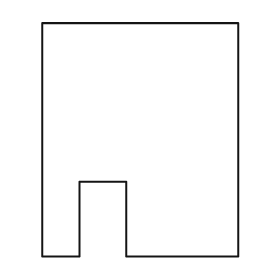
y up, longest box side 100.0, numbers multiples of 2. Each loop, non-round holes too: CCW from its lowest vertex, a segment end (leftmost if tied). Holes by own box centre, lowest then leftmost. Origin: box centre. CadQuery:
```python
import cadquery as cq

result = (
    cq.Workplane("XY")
    .moveTo(-42.0, -50.0)
    .lineTo(-26.0, -50.0)
    .lineTo(-26.0, -18.0)
    .lineTo(-6.0, -18.0)
    .lineTo(-6.0, -50.0)
    .lineTo(42.0, -50.0)
    .lineTo(42.0, 50.0)
    .lineTo(-42.0, 50.0)
    .close()
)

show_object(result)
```